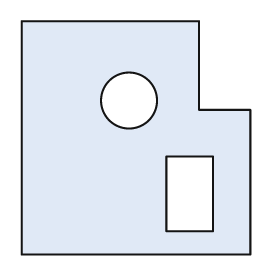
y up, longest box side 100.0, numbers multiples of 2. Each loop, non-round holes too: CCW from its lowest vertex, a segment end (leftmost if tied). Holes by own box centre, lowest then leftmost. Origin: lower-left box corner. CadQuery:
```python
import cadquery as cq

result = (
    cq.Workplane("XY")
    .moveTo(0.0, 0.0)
    .lineTo(98.0, 0.0)
    .lineTo(98.0, 62.0)
    .lineTo(76.0, 62.0)
    .lineTo(76.0, 100.0)
    .lineTo(0.0, 100.0)
    .close()
    .moveTo(62.0, 10.0)
    .lineTo(82.0, 10.0)
    .lineTo(82.0, 42.0)
    .lineTo(62.0, 42.0)
    .close()
    .moveTo(46.0, 66.0)
    .circle(12.0)
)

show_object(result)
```